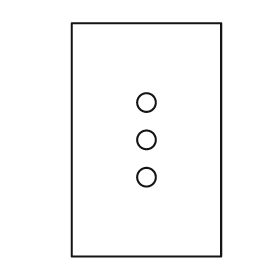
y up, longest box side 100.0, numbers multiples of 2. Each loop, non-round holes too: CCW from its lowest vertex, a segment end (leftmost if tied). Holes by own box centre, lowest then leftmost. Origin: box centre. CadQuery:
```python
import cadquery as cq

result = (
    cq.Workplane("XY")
    .moveTo(-32.0, -50.0)
    .lineTo(32.0, -50.0)
    .lineTo(32.0, 50.0)
    .lineTo(-32.0, 50.0)
    .close()
    .moveTo(0.0, -16.0)
    .circle(4.0)
    .moveTo(0.0, 0.0)
    .circle(4.0)
    .moveTo(0.0, 16.0)
    .circle(4.0)
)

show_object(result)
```